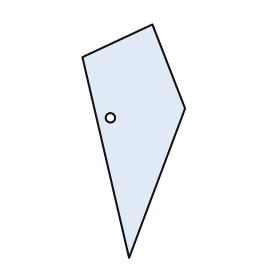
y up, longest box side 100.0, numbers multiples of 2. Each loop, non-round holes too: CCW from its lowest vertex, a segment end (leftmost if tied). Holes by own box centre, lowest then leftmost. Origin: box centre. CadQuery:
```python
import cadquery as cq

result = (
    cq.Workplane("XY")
    .moveTo(-2.0, -50.0)
    .lineTo(22.0, 14.0)
    .lineTo(8.0, 50.0)
    .lineTo(-22.0, 36.0)
    .close()
    .moveTo(-10.0, 10.0)
    .circle(2.0)
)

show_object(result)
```